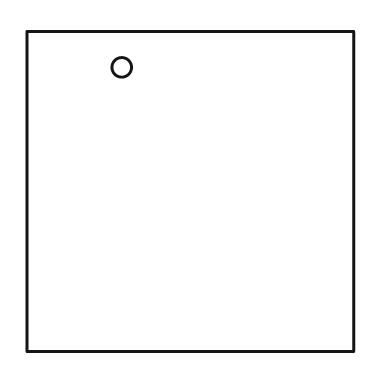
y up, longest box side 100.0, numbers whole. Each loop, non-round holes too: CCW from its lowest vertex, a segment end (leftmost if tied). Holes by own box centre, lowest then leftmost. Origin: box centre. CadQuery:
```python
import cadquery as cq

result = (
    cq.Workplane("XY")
    .moveTo(-50.0, -49.0)
    .lineTo(50.0, -49.0)
    .lineTo(50.0, 49.0)
    .lineTo(-50.0, 49.0)
    .close()
    .moveTo(-21.0, 38.0)
    .circle(3.0)
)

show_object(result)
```